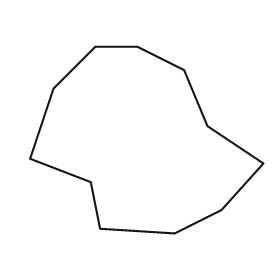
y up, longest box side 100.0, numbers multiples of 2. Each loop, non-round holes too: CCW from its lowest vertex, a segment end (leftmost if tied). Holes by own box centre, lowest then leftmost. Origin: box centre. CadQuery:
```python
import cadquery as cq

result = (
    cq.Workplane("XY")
    .moveTo(12.0, -40.0)
    .lineTo(32.0, -30.0)
    .lineTo(50.0, -10.0)
    .lineTo(26.0, 6.0)
    .lineTo(16.0, 30.0)
    .lineTo(-4.0, 40.0)
    .lineTo(-22.0, 40.0)
    .lineTo(-40.0, 22.0)
    .lineTo(-50.0, -8.0)
    .lineTo(-24.0, -18.0)
    .lineTo(-20.0, -38.0)
    .close()
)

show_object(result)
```